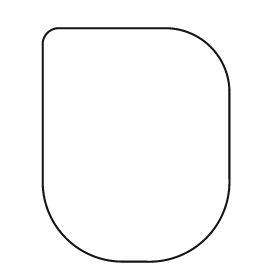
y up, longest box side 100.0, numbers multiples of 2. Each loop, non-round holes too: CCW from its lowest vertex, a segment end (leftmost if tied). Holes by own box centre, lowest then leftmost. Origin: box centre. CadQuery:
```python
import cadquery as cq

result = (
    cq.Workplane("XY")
    .moveTo(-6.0, -50.0)
    .lineTo(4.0, -50.0)
    .threePointArc((30.0, -40.0), (40.0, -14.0))
    .lineTo(40.0, 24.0)
    .threePointArc((32.0, 42.0), (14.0, 50.0))
    .lineTo(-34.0, 50.0)
    .threePointArc((-38.0, 48.0), (-40.0, 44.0))
    .lineTo(-40.0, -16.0)
    .threePointArc((-30.0, -40.0), (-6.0, -50.0))
    .close()
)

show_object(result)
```